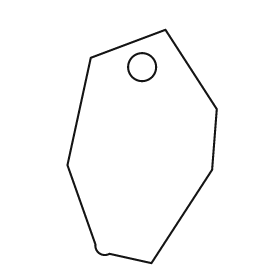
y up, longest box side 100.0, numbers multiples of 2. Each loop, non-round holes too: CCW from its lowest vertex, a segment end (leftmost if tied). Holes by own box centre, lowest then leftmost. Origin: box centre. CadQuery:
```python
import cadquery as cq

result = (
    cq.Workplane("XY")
    .moveTo(4.0, -50.0)
    .lineTo(30.0, -10.0)
    .lineTo(32.0, 16.0)
    .lineTo(10.0, 50.0)
    .lineTo(-22.0, 38.0)
    .lineTo(-32.0, -8.0)
    .lineTo(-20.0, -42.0)
    .threePointArc((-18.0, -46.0), (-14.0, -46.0))
    .close()
    .moveTo(0.0, 34.0)
    .circle(6.0)
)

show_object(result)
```